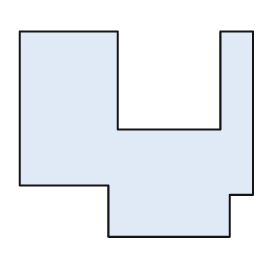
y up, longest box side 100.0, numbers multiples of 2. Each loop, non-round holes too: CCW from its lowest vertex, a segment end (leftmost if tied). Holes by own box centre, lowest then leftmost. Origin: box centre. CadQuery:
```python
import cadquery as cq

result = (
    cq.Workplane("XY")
    .moveTo(-12.0, -44.0)
    .lineTo(40.0, -44.0)
    .lineTo(40.0, -26.0)
    .lineTo(50.0, -26.0)
    .lineTo(50.0, 44.0)
    .lineTo(36.0, 44.0)
    .lineTo(36.0, 2.0)
    .lineTo(-8.0, 2.0)
    .lineTo(-8.0, 44.0)
    .lineTo(-50.0, 44.0)
    .lineTo(-50.0, -22.0)
    .lineTo(-12.0, -22.0)
    .close()
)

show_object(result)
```